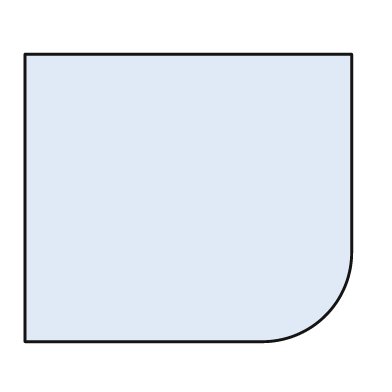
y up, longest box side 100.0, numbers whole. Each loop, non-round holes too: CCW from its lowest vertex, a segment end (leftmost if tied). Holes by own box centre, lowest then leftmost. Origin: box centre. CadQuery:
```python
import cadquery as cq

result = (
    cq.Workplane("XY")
    .moveTo(-50.0, -44.0)
    .lineTo(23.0, -44.0)
    .threePointArc((42.0, -36.0), (50.0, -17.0))
    .lineTo(50.0, 44.0)
    .lineTo(-50.0, 44.0)
    .close()
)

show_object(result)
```